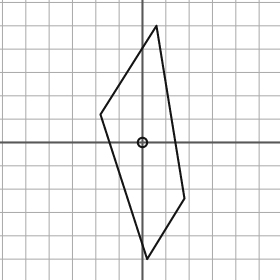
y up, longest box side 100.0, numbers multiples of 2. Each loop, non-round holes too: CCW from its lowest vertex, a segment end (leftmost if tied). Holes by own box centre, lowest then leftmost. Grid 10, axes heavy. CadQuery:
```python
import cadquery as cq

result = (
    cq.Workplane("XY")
    .moveTo(2.0, -50.0)
    .lineTo(18.0, -24.0)
    .lineTo(6.0, 50.0)
    .lineTo(-18.0, 12.0)
    .close()
    .moveTo(0.0, 0.0)
    .circle(2.0)
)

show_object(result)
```